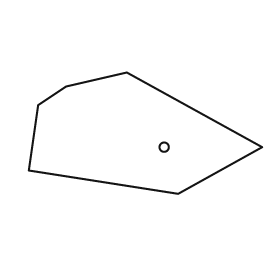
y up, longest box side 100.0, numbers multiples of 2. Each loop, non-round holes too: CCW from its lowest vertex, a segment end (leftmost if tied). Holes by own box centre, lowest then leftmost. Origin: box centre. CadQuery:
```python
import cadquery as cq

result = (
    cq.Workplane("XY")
    .moveTo(14.0, -26.0)
    .lineTo(50.0, -6.0)
    .lineTo(-8.0, 26.0)
    .lineTo(-34.0, 20.0)
    .lineTo(-46.0, 12.0)
    .lineTo(-50.0, -16.0)
    .close()
    .moveTo(8.0, -6.0)
    .circle(2.0)
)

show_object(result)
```